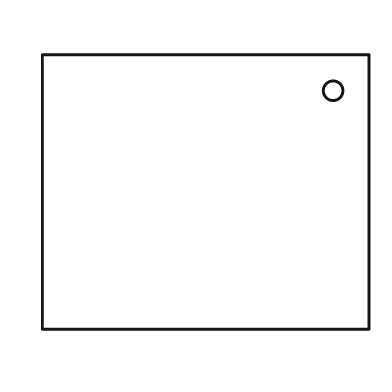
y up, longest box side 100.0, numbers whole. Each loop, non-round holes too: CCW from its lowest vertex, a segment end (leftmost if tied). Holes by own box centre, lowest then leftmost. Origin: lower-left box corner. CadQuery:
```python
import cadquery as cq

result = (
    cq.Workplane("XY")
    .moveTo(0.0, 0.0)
    .lineTo(100.0, 0.0)
    .lineTo(100.0, 84.0)
    .lineTo(0.0, 84.0)
    .close()
    .moveTo(89.0, 73.0)
    .circle(3.0)
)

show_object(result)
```